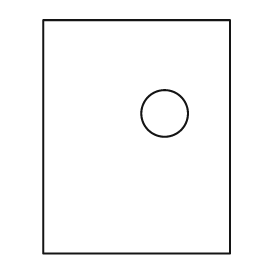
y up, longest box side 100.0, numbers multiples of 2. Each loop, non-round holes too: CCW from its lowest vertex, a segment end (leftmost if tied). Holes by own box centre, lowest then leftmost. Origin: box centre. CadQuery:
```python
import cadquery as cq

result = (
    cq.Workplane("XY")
    .moveTo(-40.0, -50.0)
    .lineTo(40.0, -50.0)
    .lineTo(40.0, 50.0)
    .lineTo(-40.0, 50.0)
    .close()
    .moveTo(12.0, 10.0)
    .circle(10.0)
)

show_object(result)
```